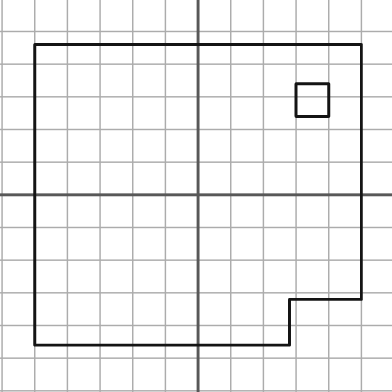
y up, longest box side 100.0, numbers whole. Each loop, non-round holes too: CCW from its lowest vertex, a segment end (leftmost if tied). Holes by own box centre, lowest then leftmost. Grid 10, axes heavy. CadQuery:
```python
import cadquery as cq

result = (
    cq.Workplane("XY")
    .moveTo(-50.0, -46.0)
    .lineTo(28.0, -46.0)
    .lineTo(28.0, -32.0)
    .lineTo(50.0, -32.0)
    .lineTo(50.0, 46.0)
    .lineTo(-50.0, 46.0)
    .close()
    .moveTo(30.0, 24.0)
    .lineTo(40.0, 24.0)
    .lineTo(40.0, 34.0)
    .lineTo(30.0, 34.0)
    .close()
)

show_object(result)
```